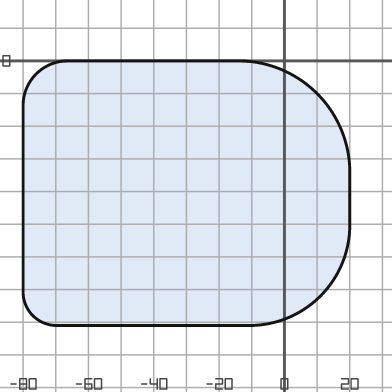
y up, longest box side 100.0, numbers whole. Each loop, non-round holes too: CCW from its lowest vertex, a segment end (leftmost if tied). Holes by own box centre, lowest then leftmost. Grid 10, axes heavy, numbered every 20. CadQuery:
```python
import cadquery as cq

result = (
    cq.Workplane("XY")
    .moveTo(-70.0, -81.0)
    .lineTo(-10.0, -81.0)
    .threePointArc((11.0, -72.0), (20.0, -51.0))
    .lineTo(20.0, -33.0)
    .threePointArc((10.0, -10.0), (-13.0, 0.0))
    .lineTo(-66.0, 0.0)
    .threePointArc((-76.0, -4.0), (-80.0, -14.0))
    .lineTo(-80.0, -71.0)
    .threePointArc((-77.0, -78.0), (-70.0, -81.0))
    .close()
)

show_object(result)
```